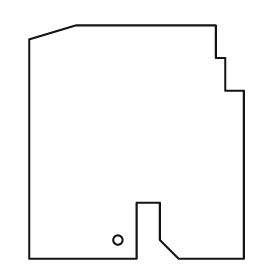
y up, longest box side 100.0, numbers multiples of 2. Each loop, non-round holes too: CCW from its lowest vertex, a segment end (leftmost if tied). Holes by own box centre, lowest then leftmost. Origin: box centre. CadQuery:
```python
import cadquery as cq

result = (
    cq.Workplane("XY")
    .moveTo(-46.0, -50.0)
    .lineTo(0.0, -50.0)
    .lineTo(0.0, -26.0)
    .lineTo(10.0, -26.0)
    .lineTo(10.0, -42.0)
    .lineTo(18.0, -50.0)
    .lineTo(46.0, -50.0)
    .lineTo(46.0, 22.0)
    .lineTo(38.0, 22.0)
    .lineTo(38.0, 36.0)
    .lineTo(34.0, 36.0)
    .lineTo(34.0, 50.0)
    .lineTo(-26.0, 50.0)
    .lineTo(-46.0, 44.0)
    .close()
    .moveTo(-8.0, -42.0)
    .circle(2.0)
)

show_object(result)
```